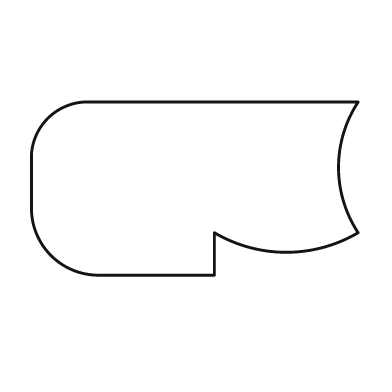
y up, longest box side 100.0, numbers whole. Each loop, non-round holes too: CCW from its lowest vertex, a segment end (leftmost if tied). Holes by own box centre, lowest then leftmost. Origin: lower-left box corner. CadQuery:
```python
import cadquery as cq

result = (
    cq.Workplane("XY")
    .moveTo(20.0, 0.0)
    .lineTo(56.0, 0.0)
    .lineTo(56.0, 13.0)
    .threePointArc((78.0, 7.0), (100.0, 13.0))
    .threePointArc((94.0, 33.0), (100.0, 53.0))
    .lineTo(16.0, 53.0)
    .threePointArc((5.0, 48.0), (0.0, 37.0))
    .lineTo(0.0, 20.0)
    .threePointArc((6.0, 6.0), (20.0, 0.0))
    .close()
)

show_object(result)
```